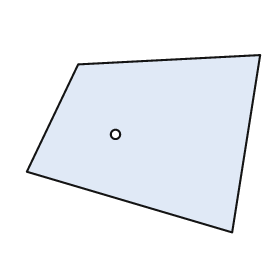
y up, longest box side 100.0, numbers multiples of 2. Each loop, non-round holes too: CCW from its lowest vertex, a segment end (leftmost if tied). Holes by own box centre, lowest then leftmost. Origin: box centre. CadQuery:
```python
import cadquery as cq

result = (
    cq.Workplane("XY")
    .moveTo(38.0, -38.0)
    .lineTo(50.0, 38.0)
    .lineTo(-28.0, 34.0)
    .lineTo(-50.0, -12.0)
    .close()
    .moveTo(-12.0, 4.0)
    .circle(2.0)
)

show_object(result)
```